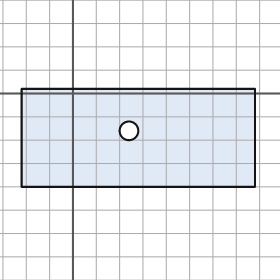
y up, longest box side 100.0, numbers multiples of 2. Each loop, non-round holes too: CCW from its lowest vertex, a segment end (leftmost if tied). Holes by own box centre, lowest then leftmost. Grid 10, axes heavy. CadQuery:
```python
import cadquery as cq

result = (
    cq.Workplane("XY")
    .moveTo(-22.0, -40.0)
    .lineTo(78.0, -40.0)
    .lineTo(78.0, 2.0)
    .lineTo(-22.0, 2.0)
    .close()
    .moveTo(24.0, -16.0)
    .circle(4.0)
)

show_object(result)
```